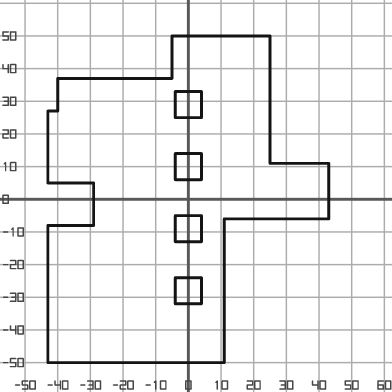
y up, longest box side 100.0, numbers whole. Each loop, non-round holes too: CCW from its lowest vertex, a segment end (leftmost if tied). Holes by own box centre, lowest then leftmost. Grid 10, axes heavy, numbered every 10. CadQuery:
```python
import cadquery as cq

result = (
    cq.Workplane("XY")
    .moveTo(-43.0, -50.0)
    .lineTo(11.0, -50.0)
    .lineTo(11.0, -6.0)
    .lineTo(43.0, -6.0)
    .lineTo(43.0, 11.0)
    .lineTo(25.0, 11.0)
    .lineTo(25.0, 50.0)
    .lineTo(-5.0, 50.0)
    .lineTo(-5.0, 37.0)
    .lineTo(-40.0, 37.0)
    .lineTo(-40.0, 27.0)
    .lineTo(-43.0, 27.0)
    .lineTo(-43.0, 5.0)
    .lineTo(-29.0, 5.0)
    .lineTo(-29.0, -8.0)
    .lineTo(-43.0, -8.0)
    .close()
    .moveTo(-4.0, -32.0)
    .lineTo(4.0, -32.0)
    .lineTo(4.0, -24.0)
    .lineTo(-4.0, -24.0)
    .close()
    .moveTo(-4.0, -13.0)
    .lineTo(4.0, -13.0)
    .lineTo(4.0, -5.0)
    .lineTo(-4.0, -5.0)
    .close()
    .moveTo(-4.0, 6.0)
    .lineTo(4.0, 6.0)
    .lineTo(4.0, 14.0)
    .lineTo(-4.0, 14.0)
    .close()
    .moveTo(-4.0, 25.0)
    .lineTo(4.0, 25.0)
    .lineTo(4.0, 33.0)
    .lineTo(-4.0, 33.0)
    .close()
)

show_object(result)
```